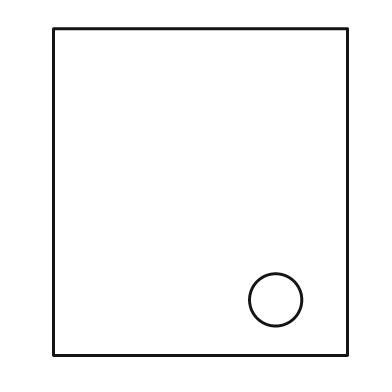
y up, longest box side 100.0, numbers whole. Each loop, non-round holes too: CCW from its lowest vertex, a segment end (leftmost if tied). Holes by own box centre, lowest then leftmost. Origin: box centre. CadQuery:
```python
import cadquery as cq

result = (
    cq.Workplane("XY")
    .moveTo(-45.0, -50.0)
    .lineTo(45.0, -50.0)
    .lineTo(45.0, 50.0)
    .lineTo(-45.0, 50.0)
    .close()
    .moveTo(23.0, -33.0)
    .circle(8.0)
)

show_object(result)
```